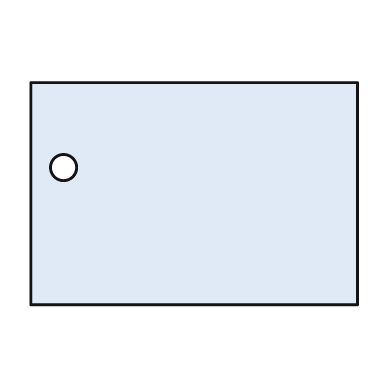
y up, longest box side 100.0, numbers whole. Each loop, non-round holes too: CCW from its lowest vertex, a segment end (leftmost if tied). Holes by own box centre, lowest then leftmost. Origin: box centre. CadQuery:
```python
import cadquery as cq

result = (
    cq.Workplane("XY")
    .moveTo(-50.0, -34.0)
    .lineTo(50.0, -34.0)
    .lineTo(50.0, 34.0)
    .lineTo(-50.0, 34.0)
    .close()
    .moveTo(-40.0, 8.0)
    .circle(4.0)
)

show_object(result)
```